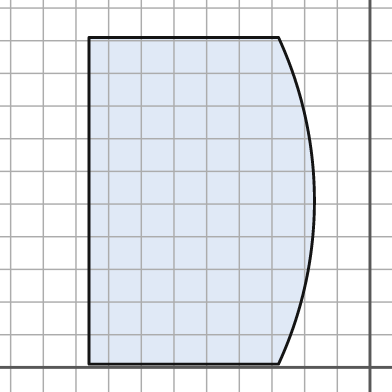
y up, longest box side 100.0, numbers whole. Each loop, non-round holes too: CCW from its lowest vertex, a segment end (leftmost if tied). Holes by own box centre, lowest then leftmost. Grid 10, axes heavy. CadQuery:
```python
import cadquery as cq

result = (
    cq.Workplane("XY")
    .moveTo(-86.0, 1.0)
    .lineTo(-28.0, 1.0)
    .threePointArc((-17.0, 51.0), (-28.0, 101.0))
    .lineTo(-86.0, 101.0)
    .close()
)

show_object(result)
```